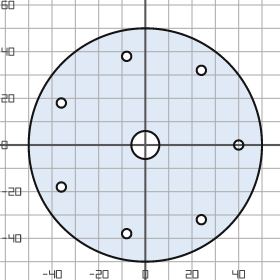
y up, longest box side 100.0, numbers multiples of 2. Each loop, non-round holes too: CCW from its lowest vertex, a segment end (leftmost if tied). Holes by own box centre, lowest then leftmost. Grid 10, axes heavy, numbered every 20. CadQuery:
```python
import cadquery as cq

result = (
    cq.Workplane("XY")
    .moveTo(0.0, 0.0)
    .circle(50.0)
    .moveTo(-8.0, -38.0)
    .circle(2.0)
    .moveTo(24.0, -32.0)
    .circle(2.0)
    .moveTo(-36.0, -18.0)
    .circle(2.0)
    .moveTo(0.0, 0.0)
    .circle(6.0)
    .moveTo(40.0, 0.0)
    .circle(2.0)
    .moveTo(-36.0, 18.0)
    .circle(2.0)
    .moveTo(24.0, 32.0)
    .circle(2.0)
    .moveTo(-8.0, 38.0)
    .circle(2.0)
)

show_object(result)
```